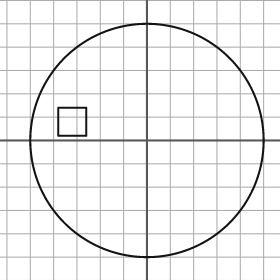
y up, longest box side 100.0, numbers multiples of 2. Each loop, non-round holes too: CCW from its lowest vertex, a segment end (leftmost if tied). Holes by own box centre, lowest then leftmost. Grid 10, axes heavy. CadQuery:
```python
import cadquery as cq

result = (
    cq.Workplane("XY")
    .moveTo(0.0, 0.0)
    .circle(50.0)
    .moveTo(-38.0, 2.0)
    .lineTo(-26.0, 2.0)
    .lineTo(-26.0, 14.0)
    .lineTo(-38.0, 14.0)
    .close()
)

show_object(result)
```